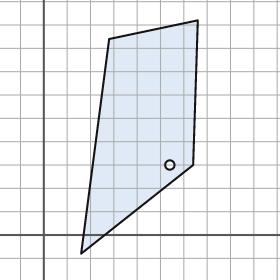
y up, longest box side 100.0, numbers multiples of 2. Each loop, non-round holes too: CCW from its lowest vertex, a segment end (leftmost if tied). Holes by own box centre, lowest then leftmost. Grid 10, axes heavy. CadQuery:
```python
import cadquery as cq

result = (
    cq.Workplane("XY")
    .moveTo(16.0, -8.0)
    .lineTo(64.0, 30.0)
    .lineTo(66.0, 92.0)
    .lineTo(28.0, 84.0)
    .close()
    .moveTo(54.0, 30.0)
    .circle(2.0)
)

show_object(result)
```